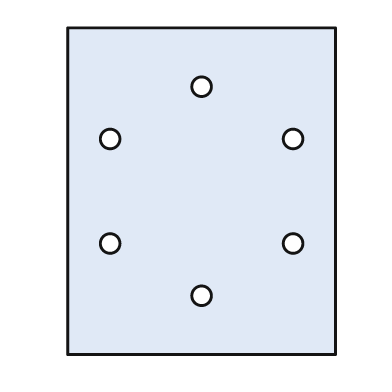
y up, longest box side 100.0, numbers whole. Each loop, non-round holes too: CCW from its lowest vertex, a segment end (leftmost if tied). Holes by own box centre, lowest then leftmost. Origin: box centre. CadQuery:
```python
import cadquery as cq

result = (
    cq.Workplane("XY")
    .moveTo(-41.0, -50.0)
    .lineTo(41.0, -50.0)
    .lineTo(41.0, 50.0)
    .lineTo(-41.0, 50.0)
    .close()
    .moveTo(0.0, -32.0)
    .circle(3.0)
    .moveTo(-28.0, -16.0)
    .circle(3.0)
    .moveTo(28.0, -16.0)
    .circle(3.0)
    .moveTo(-28.0, 16.0)
    .circle(3.0)
    .moveTo(28.0, 16.0)
    .circle(3.0)
    .moveTo(0.0, 32.0)
    .circle(3.0)
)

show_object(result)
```